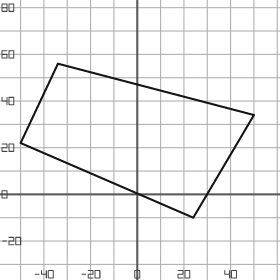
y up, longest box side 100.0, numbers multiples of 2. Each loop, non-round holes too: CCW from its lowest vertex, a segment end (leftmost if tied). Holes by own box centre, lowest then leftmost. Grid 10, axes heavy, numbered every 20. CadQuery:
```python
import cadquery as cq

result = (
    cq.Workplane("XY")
    .moveTo(24.0, -10.0)
    .lineTo(50.0, 34.0)
    .lineTo(-34.0, 56.0)
    .lineTo(-50.0, 22.0)
    .close()
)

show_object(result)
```